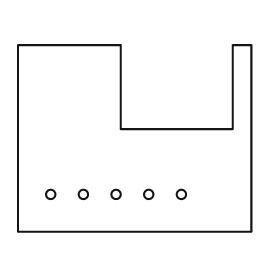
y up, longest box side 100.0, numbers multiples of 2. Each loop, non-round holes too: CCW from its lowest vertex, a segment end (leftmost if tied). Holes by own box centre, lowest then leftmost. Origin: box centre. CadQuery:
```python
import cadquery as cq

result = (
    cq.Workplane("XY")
    .moveTo(-50.0, -40.0)
    .lineTo(50.0, -40.0)
    .lineTo(50.0, 40.0)
    .lineTo(42.0, 40.0)
    .lineTo(42.0, 4.0)
    .lineTo(-6.0, 4.0)
    .lineTo(-6.0, 40.0)
    .lineTo(-50.0, 40.0)
    .close()
    .moveTo(-36.0, -24.0)
    .circle(2.0)
    .moveTo(-22.0, -24.0)
    .circle(2.0)
    .moveTo(-8.0, -24.0)
    .circle(2.0)
    .moveTo(6.0, -24.0)
    .circle(2.0)
    .moveTo(20.0, -24.0)
    .circle(2.0)
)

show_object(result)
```